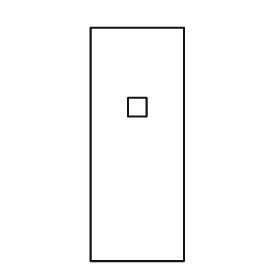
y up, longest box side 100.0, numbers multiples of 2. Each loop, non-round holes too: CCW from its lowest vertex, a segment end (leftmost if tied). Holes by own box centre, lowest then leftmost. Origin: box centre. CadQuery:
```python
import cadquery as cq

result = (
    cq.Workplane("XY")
    .moveTo(-20.0, -50.0)
    .lineTo(20.0, -50.0)
    .lineTo(20.0, 50.0)
    .lineTo(-20.0, 50.0)
    .close()
    .moveTo(-4.0, 12.0)
    .lineTo(4.0, 12.0)
    .lineTo(4.0, 20.0)
    .lineTo(-4.0, 20.0)
    .close()
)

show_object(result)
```